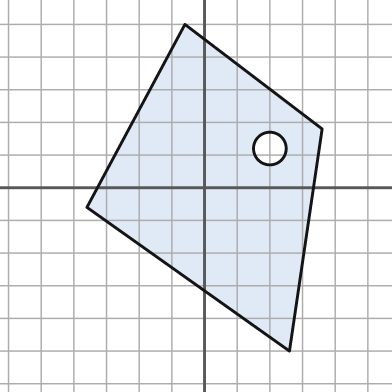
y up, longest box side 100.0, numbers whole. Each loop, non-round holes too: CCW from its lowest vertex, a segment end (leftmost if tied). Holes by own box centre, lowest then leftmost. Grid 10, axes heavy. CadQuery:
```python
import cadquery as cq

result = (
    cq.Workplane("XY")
    .moveTo(26.0, -50.0)
    .lineTo(36.0, 18.0)
    .lineTo(-6.0, 50.0)
    .lineTo(-36.0, -6.0)
    .close()
    .moveTo(20.0, 12.0)
    .circle(5.0)
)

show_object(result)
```